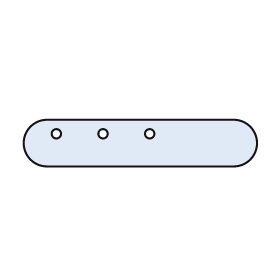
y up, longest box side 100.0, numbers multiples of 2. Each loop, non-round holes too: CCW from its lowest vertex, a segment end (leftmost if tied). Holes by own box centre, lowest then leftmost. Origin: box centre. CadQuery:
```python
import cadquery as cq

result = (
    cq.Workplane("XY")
    .moveTo(-40.0, -10.0)
    .lineTo(40.0, -10.0)
    .threePointArc((50.0, 0.0), (40.0, 10.0))
    .lineTo(-40.0, 10.0)
    .threePointArc((-50.0, 0.0), (-40.0, -10.0))
    .close()
    .moveTo(-36.0, 4.0)
    .circle(2.0)
    .moveTo(-16.0, 4.0)
    .circle(2.0)
    .moveTo(4.0, 4.0)
    .circle(2.0)
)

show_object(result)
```